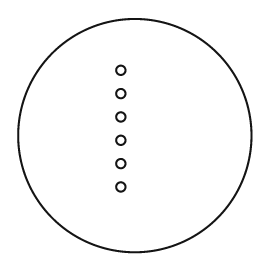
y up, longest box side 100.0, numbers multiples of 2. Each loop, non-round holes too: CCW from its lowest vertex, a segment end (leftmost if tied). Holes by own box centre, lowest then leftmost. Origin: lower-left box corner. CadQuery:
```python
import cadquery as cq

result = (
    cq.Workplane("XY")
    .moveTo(50.0, 50.0)
    .circle(50.0)
    .moveTo(44.0, 28.0)
    .circle(2.0)
    .moveTo(44.0, 38.0)
    .circle(2.0)
    .moveTo(44.0, 48.0)
    .circle(2.0)
    .moveTo(44.0, 58.0)
    .circle(2.0)
    .moveTo(44.0, 68.0)
    .circle(2.0)
    .moveTo(44.0, 78.0)
    .circle(2.0)
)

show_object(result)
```